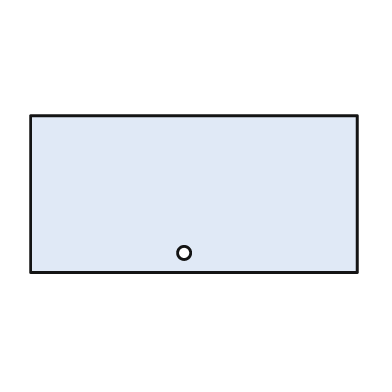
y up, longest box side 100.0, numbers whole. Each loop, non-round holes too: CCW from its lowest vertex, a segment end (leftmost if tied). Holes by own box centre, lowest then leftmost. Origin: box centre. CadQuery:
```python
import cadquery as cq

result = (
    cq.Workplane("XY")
    .moveTo(-50.0, -24.0)
    .lineTo(50.0, -24.0)
    .lineTo(50.0, 24.0)
    .lineTo(-50.0, 24.0)
    .close()
    .moveTo(-3.0, -18.0)
    .circle(2.0)
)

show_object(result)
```